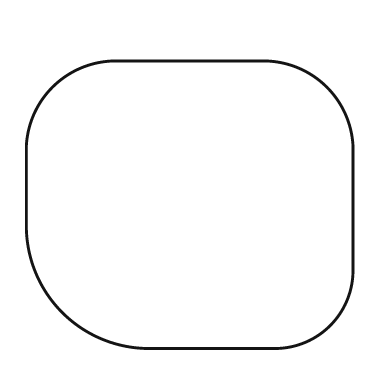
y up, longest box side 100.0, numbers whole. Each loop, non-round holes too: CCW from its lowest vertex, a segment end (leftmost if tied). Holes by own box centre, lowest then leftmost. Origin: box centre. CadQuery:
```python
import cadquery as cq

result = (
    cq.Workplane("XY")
    .moveTo(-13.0, -44.0)
    .lineTo(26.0, -44.0)
    .threePointArc((43.0, -37.0), (50.0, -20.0))
    .lineTo(50.0, 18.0)
    .threePointArc((42.0, 36.0), (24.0, 44.0))
    .lineTo(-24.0, 44.0)
    .threePointArc((-42.0, 36.0), (-50.0, 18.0))
    .lineTo(-50.0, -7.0)
    .threePointArc((-39.0, -33.0), (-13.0, -44.0))
    .close()
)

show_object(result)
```